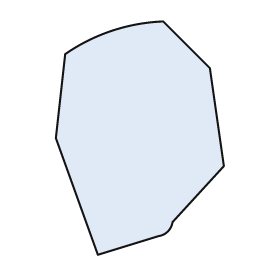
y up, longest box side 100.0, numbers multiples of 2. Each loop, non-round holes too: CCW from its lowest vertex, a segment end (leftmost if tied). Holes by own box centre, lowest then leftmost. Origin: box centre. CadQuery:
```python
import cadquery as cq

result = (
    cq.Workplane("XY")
    .moveTo(-18.0, -50.0)
    .lineTo(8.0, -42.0)
    .threePointArc((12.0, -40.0), (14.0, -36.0))
    .lineTo(36.0, -12.0)
    .lineTo(30.0, 30.0)
    .lineTo(10.0, 50.0)
    .threePointArc((-12.0, 46.0), (-32.0, 36.0))
    .lineTo(-36.0, 0.0)
    .close()
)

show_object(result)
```